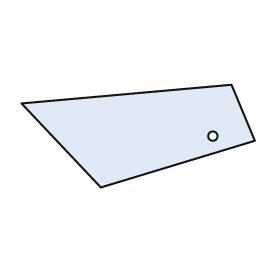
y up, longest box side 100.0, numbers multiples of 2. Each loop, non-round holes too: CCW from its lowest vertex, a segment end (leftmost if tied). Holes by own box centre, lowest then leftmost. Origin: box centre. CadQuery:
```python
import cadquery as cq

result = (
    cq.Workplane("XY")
    .moveTo(-16.0, -22.0)
    .lineTo(50.0, -2.0)
    .lineTo(40.0, 22.0)
    .lineTo(-50.0, 14.0)
    .close()
    .moveTo(32.0, 0.0)
    .circle(2.0)
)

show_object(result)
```